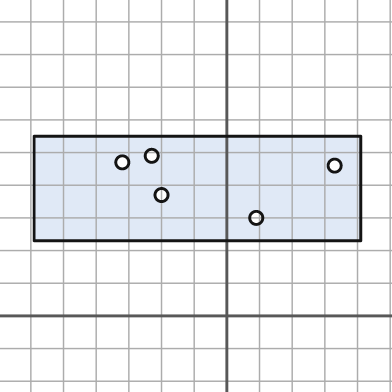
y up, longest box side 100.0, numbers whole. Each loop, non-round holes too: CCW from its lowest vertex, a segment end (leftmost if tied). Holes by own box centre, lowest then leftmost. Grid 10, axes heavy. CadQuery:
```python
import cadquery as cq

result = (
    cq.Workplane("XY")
    .moveTo(-59.0, 23.0)
    .lineTo(41.0, 23.0)
    .lineTo(41.0, 55.0)
    .lineTo(-59.0, 55.0)
    .close()
    .moveTo(9.0, 30.0)
    .circle(2.0)
    .moveTo(-20.0, 37.0)
    .circle(2.0)
    .moveTo(33.0, 46.0)
    .circle(2.0)
    .moveTo(-32.0, 47.0)
    .circle(2.0)
    .moveTo(-23.0, 49.0)
    .circle(2.0)
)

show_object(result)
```